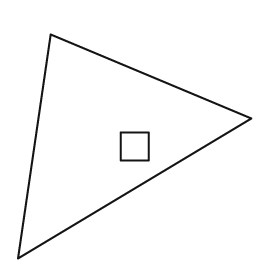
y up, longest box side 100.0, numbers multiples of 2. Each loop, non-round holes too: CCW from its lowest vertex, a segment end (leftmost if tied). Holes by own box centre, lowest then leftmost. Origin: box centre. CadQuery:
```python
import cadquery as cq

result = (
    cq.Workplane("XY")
    .moveTo(-50.0, -48.0)
    .lineTo(50.0, 12.0)
    .lineTo(-36.0, 48.0)
    .close()
    .moveTo(-6.0, -6.0)
    .lineTo(6.0, -6.0)
    .lineTo(6.0, 6.0)
    .lineTo(-6.0, 6.0)
    .close()
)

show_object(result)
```